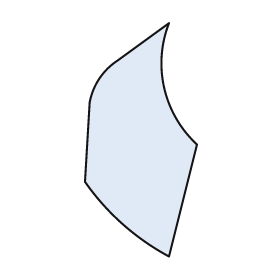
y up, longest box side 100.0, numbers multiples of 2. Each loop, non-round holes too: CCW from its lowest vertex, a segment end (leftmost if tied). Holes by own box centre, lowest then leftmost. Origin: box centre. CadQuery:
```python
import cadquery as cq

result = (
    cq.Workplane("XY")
    .moveTo(12.0, -50.0)
    .lineTo(24.0, -2.0)
    .threePointArc((10.0, 22.0), (12.0, 50.0))
    .lineTo(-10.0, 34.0)
    .threePointArc((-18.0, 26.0), (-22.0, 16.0))
    .lineTo(-24.0, -18.0)
    .threePointArc((-8.0, -36.0), (12.0, -50.0))
    .close()
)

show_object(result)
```